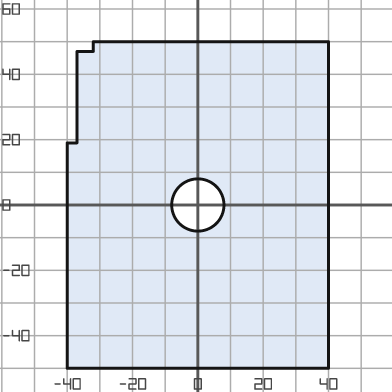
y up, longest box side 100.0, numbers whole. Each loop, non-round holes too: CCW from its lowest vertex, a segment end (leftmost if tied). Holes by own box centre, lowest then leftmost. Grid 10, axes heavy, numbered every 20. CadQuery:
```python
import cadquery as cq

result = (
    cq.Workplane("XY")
    .moveTo(-40.0, -50.0)
    .lineTo(40.0, -50.0)
    .lineTo(40.0, 50.0)
    .lineTo(-32.0, 50.0)
    .lineTo(-32.0, 47.0)
    .lineTo(-37.0, 47.0)
    .lineTo(-37.0, 19.0)
    .lineTo(-40.0, 19.0)
    .close()
    .moveTo(0.0, 0.0)
    .circle(8.0)
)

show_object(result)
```